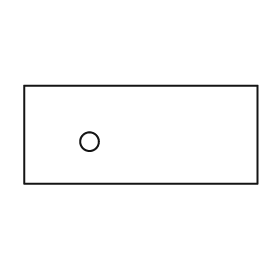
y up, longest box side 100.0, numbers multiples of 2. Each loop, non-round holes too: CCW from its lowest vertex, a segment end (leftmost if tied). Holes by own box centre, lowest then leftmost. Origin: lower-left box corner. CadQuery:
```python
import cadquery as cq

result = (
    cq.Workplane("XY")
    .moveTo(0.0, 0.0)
    .lineTo(100.0, 0.0)
    .lineTo(100.0, 42.0)
    .lineTo(0.0, 42.0)
    .close()
    .moveTo(28.0, 18.0)
    .circle(4.0)
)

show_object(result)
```